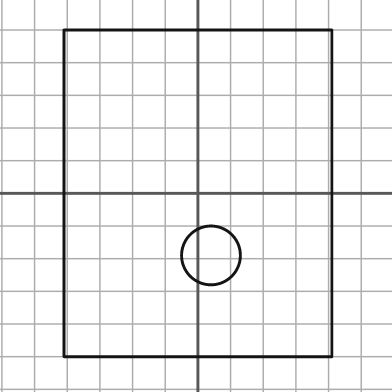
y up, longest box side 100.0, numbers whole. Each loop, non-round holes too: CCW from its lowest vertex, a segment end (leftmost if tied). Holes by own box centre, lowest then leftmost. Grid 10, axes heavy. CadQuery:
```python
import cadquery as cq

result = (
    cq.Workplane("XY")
    .moveTo(-41.0, -50.0)
    .lineTo(41.0, -50.0)
    .lineTo(41.0, 50.0)
    .lineTo(-41.0, 50.0)
    .close()
    .moveTo(4.0, -19.0)
    .circle(9.0)
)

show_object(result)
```